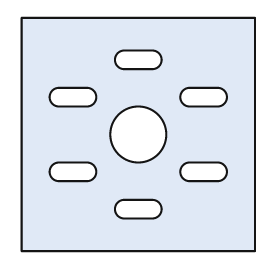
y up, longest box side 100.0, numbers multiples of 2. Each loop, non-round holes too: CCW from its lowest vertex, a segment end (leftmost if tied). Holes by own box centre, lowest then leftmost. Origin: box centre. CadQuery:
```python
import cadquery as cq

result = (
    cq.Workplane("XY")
    .moveTo(-50.0, -50.0)
    .lineTo(50.0, -50.0)
    .lineTo(50.0, 50.0)
    .lineTo(-50.0, 50.0)
    .close()
    .moveTo(-6.0, -36.0)
    .lineTo(6.0, -36.0)
    .threePointArc((10.0, -32.0), (6.0, -28.0))
    .lineTo(-6.0, -28.0)
    .threePointArc((-10.0, -32.0), (-6.0, -36.0))
    .close()
    .moveTo(-34.0, -20.0)
    .lineTo(-22.0, -20.0)
    .threePointArc((-18.0, -16.0), (-22.0, -12.0))
    .lineTo(-34.0, -12.0)
    .threePointArc((-38.0, -16.0), (-34.0, -20.0))
    .close()
    .moveTo(22.0, -20.0)
    .lineTo(34.0, -20.0)
    .threePointArc((38.0, -16.0), (34.0, -12.0))
    .lineTo(22.0, -12.0)
    .threePointArc((18.0, -16.0), (22.0, -20.0))
    .close()
    .moveTo(0.0, 0.0)
    .circle(12.0)
    .moveTo(-34.0, 12.0)
    .lineTo(-22.0, 12.0)
    .threePointArc((-18.0, 16.0), (-22.0, 20.0))
    .lineTo(-34.0, 20.0)
    .threePointArc((-38.0, 16.0), (-34.0, 12.0))
    .close()
    .moveTo(22.0, 12.0)
    .lineTo(34.0, 12.0)
    .threePointArc((38.0, 16.0), (34.0, 20.0))
    .lineTo(22.0, 20.0)
    .threePointArc((18.0, 16.0), (22.0, 12.0))
    .close()
    .moveTo(-6.0, 28.0)
    .lineTo(6.0, 28.0)
    .threePointArc((10.0, 32.0), (6.0, 36.0))
    .lineTo(-6.0, 36.0)
    .threePointArc((-10.0, 32.0), (-6.0, 28.0))
    .close()
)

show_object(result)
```